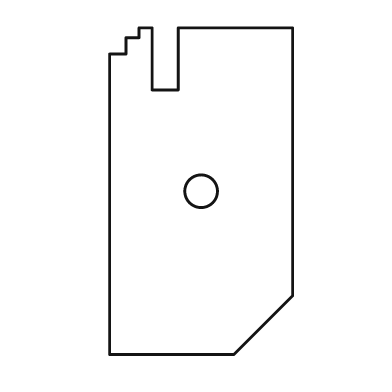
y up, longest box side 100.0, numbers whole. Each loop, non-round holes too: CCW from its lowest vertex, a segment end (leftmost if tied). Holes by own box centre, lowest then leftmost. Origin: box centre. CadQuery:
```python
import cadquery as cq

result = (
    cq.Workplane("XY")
    .moveTo(-28.0, -50.0)
    .lineTo(10.0, -50.0)
    .lineTo(28.0, -32.0)
    .lineTo(28.0, 50.0)
    .lineTo(-7.0, 50.0)
    .lineTo(-7.0, 31.0)
    .lineTo(-15.0, 31.0)
    .lineTo(-15.0, 50.0)
    .lineTo(-19.0, 50.0)
    .lineTo(-19.0, 47.0)
    .lineTo(-23.0, 47.0)
    .lineTo(-23.0, 42.0)
    .lineTo(-28.0, 42.0)
    .close()
    .moveTo(0.0, 0.0)
    .circle(5.0)
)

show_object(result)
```